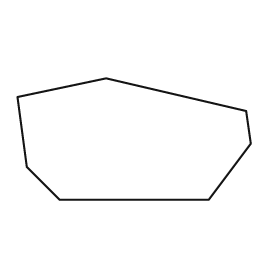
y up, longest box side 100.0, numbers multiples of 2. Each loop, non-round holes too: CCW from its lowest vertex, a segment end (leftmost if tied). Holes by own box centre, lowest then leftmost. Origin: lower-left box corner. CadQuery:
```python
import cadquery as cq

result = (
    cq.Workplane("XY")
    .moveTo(18.0, 0.0)
    .lineTo(82.0, 0.0)
    .lineTo(100.0, 24.0)
    .lineTo(98.0, 38.0)
    .lineTo(38.0, 52.0)
    .lineTo(0.0, 44.0)
    .lineTo(4.0, 14.0)
    .close()
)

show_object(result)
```